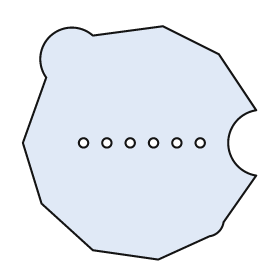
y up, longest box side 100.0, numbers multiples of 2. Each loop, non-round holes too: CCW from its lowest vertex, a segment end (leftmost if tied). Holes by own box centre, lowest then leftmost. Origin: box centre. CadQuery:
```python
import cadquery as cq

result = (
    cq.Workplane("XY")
    .moveTo(8.0, -50.0)
    .lineTo(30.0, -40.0)
    .threePointArc((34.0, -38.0), (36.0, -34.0))
    .lineTo(50.0, -14.0)
    .threePointArc((38.0, 0.0), (50.0, 14.0))
    .lineTo(34.0, 38.0)
    .lineTo(10.0, 50.0)
    .lineTo(-20.0, 46.0)
    .threePointArc((-38.0, 46.0), (-40.0, 28.0))
    .lineTo(-50.0, 0.0)
    .lineTo(-42.0, -26.0)
    .lineTo(-20.0, -46.0)
    .close()
    .moveTo(-24.0, 0.0)
    .circle(2.0)
    .moveTo(-14.0, 0.0)
    .circle(2.0)
    .moveTo(-4.0, 0.0)
    .circle(2.0)
    .moveTo(6.0, 0.0)
    .circle(2.0)
    .moveTo(16.0, 0.0)
    .circle(2.0)
    .moveTo(26.0, 0.0)
    .circle(2.0)
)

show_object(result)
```